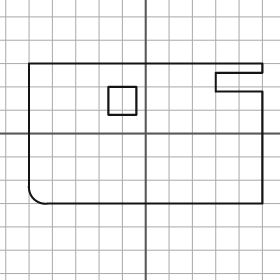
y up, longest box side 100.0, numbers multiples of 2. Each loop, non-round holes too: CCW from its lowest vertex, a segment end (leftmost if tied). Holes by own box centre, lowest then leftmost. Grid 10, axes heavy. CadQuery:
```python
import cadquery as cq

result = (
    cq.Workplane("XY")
    .moveTo(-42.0, -30.0)
    .lineTo(50.0, -30.0)
    .lineTo(50.0, 18.0)
    .lineTo(30.0, 18.0)
    .lineTo(30.0, 26.0)
    .lineTo(50.0, 26.0)
    .lineTo(50.0, 30.0)
    .lineTo(-50.0, 30.0)
    .lineTo(-50.0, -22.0)
    .threePointArc((-48.0, -28.0), (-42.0, -30.0))
    .close()
    .moveTo(-16.0, 8.0)
    .lineTo(-4.0, 8.0)
    .lineTo(-4.0, 20.0)
    .lineTo(-16.0, 20.0)
    .close()
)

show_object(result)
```